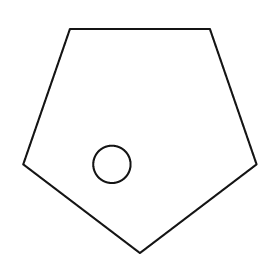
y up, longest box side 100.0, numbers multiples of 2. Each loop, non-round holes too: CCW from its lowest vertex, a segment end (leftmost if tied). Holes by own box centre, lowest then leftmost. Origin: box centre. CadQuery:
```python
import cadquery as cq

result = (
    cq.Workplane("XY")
    .moveTo(0.0, -48.0)
    .lineTo(50.0, -10.0)
    .lineTo(30.0, 48.0)
    .lineTo(-30.0, 48.0)
    .lineTo(-50.0, -10.0)
    .close()
    .moveTo(-12.0, -10.0)
    .circle(8.0)
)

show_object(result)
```